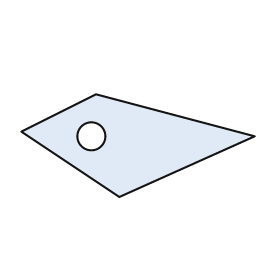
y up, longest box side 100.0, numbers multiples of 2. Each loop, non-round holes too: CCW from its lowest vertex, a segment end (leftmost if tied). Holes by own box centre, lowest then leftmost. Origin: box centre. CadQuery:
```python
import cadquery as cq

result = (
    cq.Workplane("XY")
    .moveTo(-8.0, -22.0)
    .lineTo(50.0, 4.0)
    .lineTo(-18.0, 22.0)
    .lineTo(-50.0, 6.0)
    .close()
    .moveTo(-20.0, 4.0)
    .circle(6.0)
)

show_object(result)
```